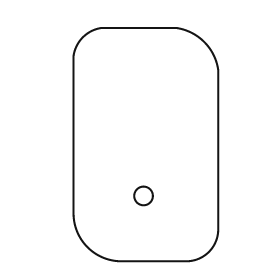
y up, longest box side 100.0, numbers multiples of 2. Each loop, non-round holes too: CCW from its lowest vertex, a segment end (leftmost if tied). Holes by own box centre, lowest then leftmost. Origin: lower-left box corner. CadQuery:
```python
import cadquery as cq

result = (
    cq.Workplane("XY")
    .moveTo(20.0, 0.0)
    .lineTo(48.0, 0.0)
    .threePointArc((58.0, 4.0), (62.0, 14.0))
    .lineTo(62.0, 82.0)
    .threePointArc((56.0, 94.0), (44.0, 100.0))
    .lineTo(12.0, 100.0)
    .threePointArc((4.0, 96.0), (0.0, 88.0))
    .lineTo(0.0, 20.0)
    .threePointArc((6.0, 6.0), (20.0, 0.0))
    .close()
    .moveTo(30.0, 28.0)
    .circle(4.0)
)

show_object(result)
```